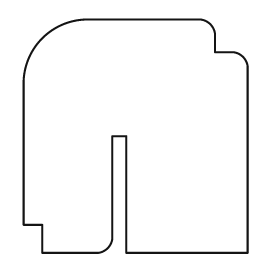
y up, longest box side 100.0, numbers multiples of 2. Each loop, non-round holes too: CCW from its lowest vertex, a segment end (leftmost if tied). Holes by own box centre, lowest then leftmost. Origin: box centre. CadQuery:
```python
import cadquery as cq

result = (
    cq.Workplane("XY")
    .moveTo(-40.0, -50.0)
    .lineTo(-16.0, -50.0)
    .threePointArc((-12.0, -48.0), (-10.0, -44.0))
    .lineTo(-10.0, 0.0)
    .lineTo(-4.0, 0.0)
    .lineTo(-4.0, -50.0)
    .lineTo(48.0, -50.0)
    .lineTo(48.0, 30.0)
    .threePointArc((46.0, 34.0), (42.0, 36.0))
    .lineTo(34.0, 36.0)
    .lineTo(34.0, 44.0)
    .threePointArc((32.0, 48.0), (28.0, 50.0))
    .lineTo(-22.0, 50.0)
    .threePointArc((-40.0, 42.0), (-48.0, 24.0))
    .lineTo(-48.0, -38.0)
    .lineTo(-40.0, -38.0)
    .close()
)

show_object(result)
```